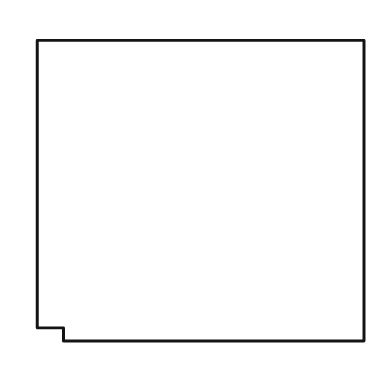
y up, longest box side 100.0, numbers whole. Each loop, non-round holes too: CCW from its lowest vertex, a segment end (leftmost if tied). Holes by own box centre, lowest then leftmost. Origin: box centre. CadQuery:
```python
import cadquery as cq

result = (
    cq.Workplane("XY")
    .moveTo(-42.0, -46.0)
    .lineTo(50.0, -46.0)
    .lineTo(50.0, 46.0)
    .lineTo(-50.0, 46.0)
    .lineTo(-50.0, -42.0)
    .lineTo(-42.0, -42.0)
    .close()
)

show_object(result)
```